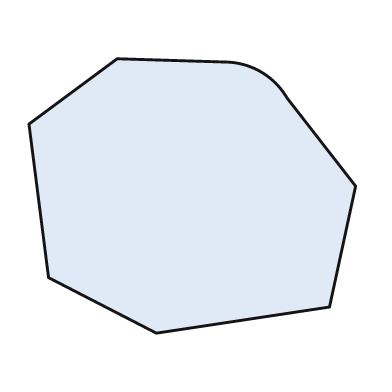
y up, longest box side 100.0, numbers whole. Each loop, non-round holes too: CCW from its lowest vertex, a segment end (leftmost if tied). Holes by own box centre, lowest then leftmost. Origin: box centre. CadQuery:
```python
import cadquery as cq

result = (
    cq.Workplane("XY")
    .moveTo(-11.0, -42.0)
    .lineTo(42.0, -34.0)
    .lineTo(50.0, 3.0)
    .lineTo(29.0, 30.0)
    .threePointArc((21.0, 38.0), (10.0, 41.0))
    .lineTo(-23.0, 42.0)
    .lineTo(-50.0, 22.0)
    .lineTo(-44.0, -25.0)
    .close()
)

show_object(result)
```